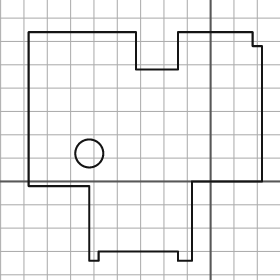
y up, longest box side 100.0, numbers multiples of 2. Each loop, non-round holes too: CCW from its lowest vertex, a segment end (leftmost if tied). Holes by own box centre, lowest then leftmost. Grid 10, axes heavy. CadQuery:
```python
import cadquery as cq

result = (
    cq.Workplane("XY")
    .moveTo(-52.0, -34.0)
    .lineTo(-48.0, -34.0)
    .lineTo(-48.0, -30.0)
    .lineTo(-14.0, -30.0)
    .lineTo(-14.0, -34.0)
    .lineTo(-8.0, -34.0)
    .lineTo(-8.0, 0.0)
    .lineTo(22.0, 0.0)
    .lineTo(22.0, 58.0)
    .lineTo(18.0, 58.0)
    .lineTo(18.0, 64.0)
    .lineTo(-14.0, 64.0)
    .lineTo(-14.0, 48.0)
    .lineTo(-32.0, 48.0)
    .lineTo(-32.0, 64.0)
    .lineTo(-78.0, 64.0)
    .lineTo(-78.0, -2.0)
    .lineTo(-52.0, -2.0)
    .close()
    .moveTo(-52.0, 12.0)
    .circle(6.0)
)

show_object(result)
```